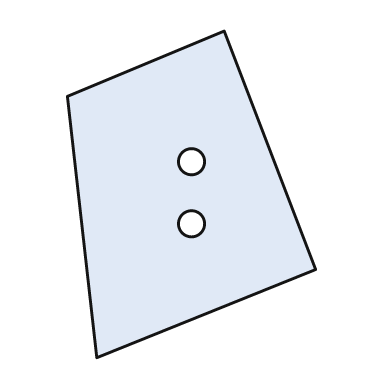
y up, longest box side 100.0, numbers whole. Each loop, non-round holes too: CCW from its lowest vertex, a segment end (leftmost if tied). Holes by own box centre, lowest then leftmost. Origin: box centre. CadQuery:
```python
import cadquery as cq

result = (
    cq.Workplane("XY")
    .moveTo(-29.0, -50.0)
    .lineTo(38.0, -23.0)
    .lineTo(10.0, 50.0)
    .lineTo(-38.0, 30.0)
    .close()
    .moveTo(0.0, -9.0)
    .circle(4.0)
    .moveTo(0.0, 10.0)
    .circle(4.0)
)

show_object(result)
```